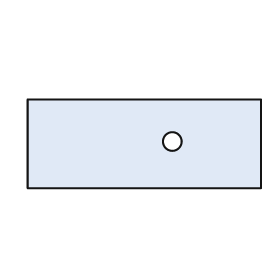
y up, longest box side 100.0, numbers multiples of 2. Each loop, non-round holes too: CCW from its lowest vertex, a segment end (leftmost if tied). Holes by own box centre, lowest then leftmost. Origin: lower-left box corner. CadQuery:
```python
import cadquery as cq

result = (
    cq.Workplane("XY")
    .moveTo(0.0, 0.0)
    .lineTo(100.0, 0.0)
    .lineTo(100.0, 38.0)
    .lineTo(0.0, 38.0)
    .close()
    .moveTo(62.0, 20.0)
    .circle(4.0)
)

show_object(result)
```